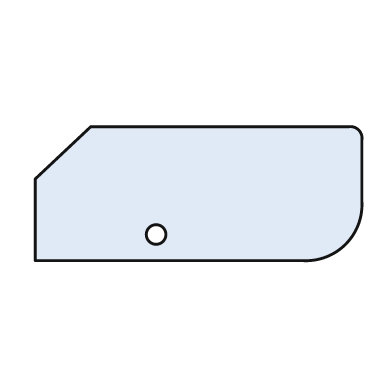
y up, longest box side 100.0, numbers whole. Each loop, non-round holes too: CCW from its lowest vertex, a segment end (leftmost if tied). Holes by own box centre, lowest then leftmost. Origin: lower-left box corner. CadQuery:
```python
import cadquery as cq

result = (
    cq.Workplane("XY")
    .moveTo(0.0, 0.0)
    .lineTo(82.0, 0.0)
    .threePointArc((95.0, 5.0), (100.0, 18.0))
    .lineTo(100.0, 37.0)
    .threePointArc((99.0, 40.0), (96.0, 41.0))
    .lineTo(17.0, 41.0)
    .lineTo(0.0, 25.0)
    .close()
    .moveTo(37.0, 8.0)
    .circle(3.0)
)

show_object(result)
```